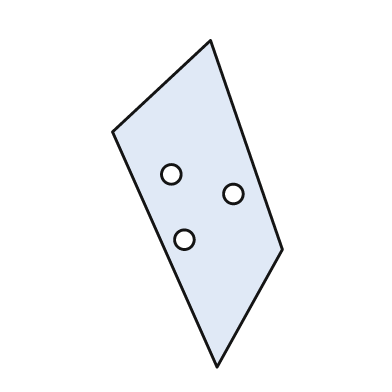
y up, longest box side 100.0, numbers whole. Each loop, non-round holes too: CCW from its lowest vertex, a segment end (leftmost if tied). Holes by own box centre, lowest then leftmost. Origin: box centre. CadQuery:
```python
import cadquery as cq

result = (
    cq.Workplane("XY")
    .moveTo(6.0, -50.0)
    .lineTo(26.0, -14.0)
    .lineTo(4.0, 50.0)
    .lineTo(-26.0, 22.0)
    .close()
    .moveTo(-4.0, -11.0)
    .circle(3.0)
    .moveTo(11.0, 3.0)
    .circle(3.0)
    .moveTo(-8.0, 9.0)
    .circle(3.0)
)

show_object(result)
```